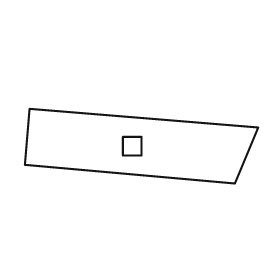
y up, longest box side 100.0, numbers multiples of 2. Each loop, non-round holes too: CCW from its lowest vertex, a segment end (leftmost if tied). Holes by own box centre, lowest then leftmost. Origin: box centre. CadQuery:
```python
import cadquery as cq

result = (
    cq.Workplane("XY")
    .moveTo(40.0, -16.0)
    .lineTo(50.0, 8.0)
    .lineTo(-48.0, 16.0)
    .lineTo(-50.0, -8.0)
    .close()
    .moveTo(-8.0, -4.0)
    .lineTo(0.0, -4.0)
    .lineTo(0.0, 4.0)
    .lineTo(-8.0, 4.0)
    .close()
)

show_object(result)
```